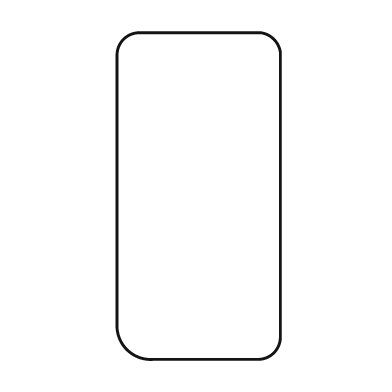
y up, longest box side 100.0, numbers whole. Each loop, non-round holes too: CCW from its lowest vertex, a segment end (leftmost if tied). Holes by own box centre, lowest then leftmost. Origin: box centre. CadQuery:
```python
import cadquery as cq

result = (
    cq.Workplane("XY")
    .moveTo(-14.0, -50.0)
    .lineTo(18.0, -50.0)
    .threePointArc((23.0, -48.0), (25.0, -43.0))
    .lineTo(25.0, 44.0)
    .threePointArc((23.0, 48.0), (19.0, 50.0))
    .lineTo(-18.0, 50.0)
    .threePointArc((-23.0, 48.0), (-25.0, 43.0))
    .lineTo(-25.0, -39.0)
    .threePointArc((-22.0, -47.0), (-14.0, -50.0))
    .close()
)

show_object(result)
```